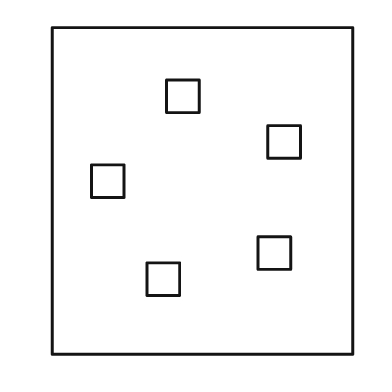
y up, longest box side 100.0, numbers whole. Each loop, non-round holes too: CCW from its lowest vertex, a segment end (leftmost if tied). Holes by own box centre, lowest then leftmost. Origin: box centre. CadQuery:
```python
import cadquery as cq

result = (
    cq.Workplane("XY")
    .moveTo(-46.0, -50.0)
    .lineTo(46.0, -50.0)
    .lineTo(46.0, 50.0)
    .lineTo(-46.0, 50.0)
    .close()
    .moveTo(-17.0, -32.0)
    .lineTo(-7.0, -32.0)
    .lineTo(-7.0, -22.0)
    .lineTo(-17.0, -22.0)
    .close()
    .moveTo(17.0, -24.0)
    .lineTo(27.0, -24.0)
    .lineTo(27.0, -14.0)
    .lineTo(17.0, -14.0)
    .close()
    .moveTo(-34.0, -2.0)
    .lineTo(-24.0, -2.0)
    .lineTo(-24.0, 8.0)
    .lineTo(-34.0, 8.0)
    .close()
    .moveTo(20.0, 10.0)
    .lineTo(30.0, 10.0)
    .lineTo(30.0, 20.0)
    .lineTo(20.0, 20.0)
    .close()
    .moveTo(-11.0, 24.0)
    .lineTo(-1.0, 24.0)
    .lineTo(-1.0, 34.0)
    .lineTo(-11.0, 34.0)
    .close()
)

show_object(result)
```